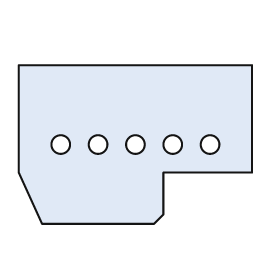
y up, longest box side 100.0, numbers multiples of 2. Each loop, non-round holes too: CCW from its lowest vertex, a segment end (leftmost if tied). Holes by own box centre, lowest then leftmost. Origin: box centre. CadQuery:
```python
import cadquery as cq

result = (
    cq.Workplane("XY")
    .moveTo(-40.0, -34.0)
    .lineTo(8.0, -34.0)
    .lineTo(12.0, -30.0)
    .lineTo(12.0, -12.0)
    .lineTo(50.0, -12.0)
    .lineTo(50.0, 34.0)
    .lineTo(-50.0, 34.0)
    .lineTo(-50.0, -12.0)
    .close()
    .moveTo(-32.0, 0.0)
    .circle(4.0)
    .moveTo(-16.0, 0.0)
    .circle(4.0)
    .moveTo(0.0, 0.0)
    .circle(4.0)
    .moveTo(16.0, 0.0)
    .circle(4.0)
    .moveTo(32.0, 0.0)
    .circle(4.0)
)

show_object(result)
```